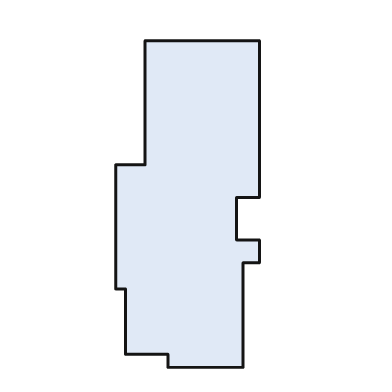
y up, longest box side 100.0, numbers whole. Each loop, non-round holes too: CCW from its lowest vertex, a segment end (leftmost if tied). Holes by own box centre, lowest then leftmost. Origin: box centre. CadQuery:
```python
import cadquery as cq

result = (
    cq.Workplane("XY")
    .moveTo(-6.0, -50.0)
    .lineTo(17.0, -50.0)
    .lineTo(17.0, -18.0)
    .lineTo(22.0, -18.0)
    .lineTo(22.0, -11.0)
    .lineTo(15.0, -11.0)
    .lineTo(15.0, 2.0)
    .lineTo(22.0, 2.0)
    .lineTo(22.0, 50.0)
    .lineTo(-13.0, 50.0)
    .lineTo(-13.0, 12.0)
    .lineTo(-22.0, 12.0)
    .lineTo(-22.0, -26.0)
    .lineTo(-19.0, -26.0)
    .lineTo(-19.0, -46.0)
    .lineTo(-6.0, -46.0)
    .close()
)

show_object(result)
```